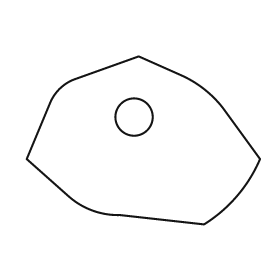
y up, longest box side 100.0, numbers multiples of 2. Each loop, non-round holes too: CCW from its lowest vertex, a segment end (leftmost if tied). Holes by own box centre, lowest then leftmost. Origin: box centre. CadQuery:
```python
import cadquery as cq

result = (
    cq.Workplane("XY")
    .moveTo(26.0, -36.0)
    .threePointArc((40.0, -24.0), (50.0, -8.0))
    .lineTo(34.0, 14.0)
    .threePointArc((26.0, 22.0), (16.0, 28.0))
    .lineTo(-2.0, 36.0)
    .lineTo(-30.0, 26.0)
    .threePointArc((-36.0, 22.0), (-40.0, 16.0))
    .lineTo(-50.0, -8.0)
    .lineTo(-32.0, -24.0)
    .threePointArc((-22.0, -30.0), (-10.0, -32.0))
    .close()
    .moveTo(-4.0, 10.0)
    .circle(8.0)
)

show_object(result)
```